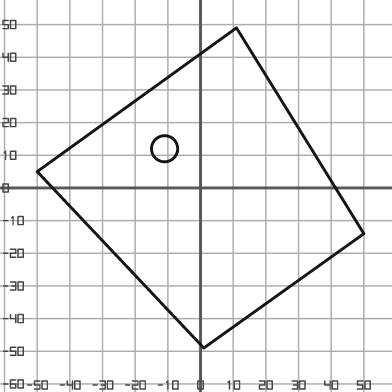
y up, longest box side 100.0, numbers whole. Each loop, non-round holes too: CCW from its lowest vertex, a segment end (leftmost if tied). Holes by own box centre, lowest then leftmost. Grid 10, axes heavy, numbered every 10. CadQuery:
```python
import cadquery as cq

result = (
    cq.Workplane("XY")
    .moveTo(1.0, -49.0)
    .lineTo(50.0, -14.0)
    .lineTo(11.0, 49.0)
    .lineTo(-50.0, 5.0)
    .close()
    .moveTo(-11.0, 12.0)
    .circle(4.0)
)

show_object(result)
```